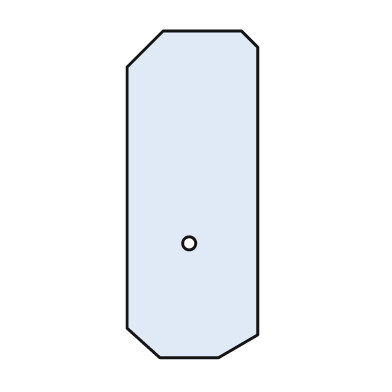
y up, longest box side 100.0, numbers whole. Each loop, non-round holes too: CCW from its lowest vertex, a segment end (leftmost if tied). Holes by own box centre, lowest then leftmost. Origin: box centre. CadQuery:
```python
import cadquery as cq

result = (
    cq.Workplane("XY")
    .moveTo(-10.0, -50.0)
    .lineTo(8.0, -50.0)
    .lineTo(20.0, -43.0)
    .lineTo(20.0, 45.0)
    .lineTo(15.0, 50.0)
    .lineTo(-9.0, 50.0)
    .lineTo(-20.0, 39.0)
    .lineTo(-20.0, -41.0)
    .close()
    .moveTo(-1.0, -15.0)
    .circle(2.0)
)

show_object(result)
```